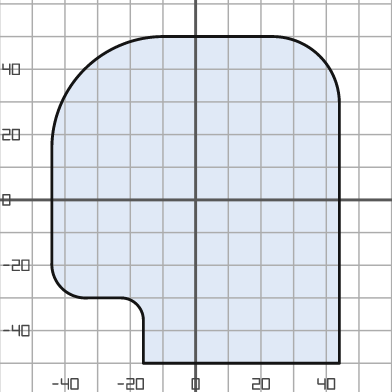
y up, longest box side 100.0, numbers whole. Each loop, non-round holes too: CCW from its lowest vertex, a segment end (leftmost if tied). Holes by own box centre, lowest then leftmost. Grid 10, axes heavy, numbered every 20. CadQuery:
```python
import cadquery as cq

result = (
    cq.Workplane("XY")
    .moveTo(-16.0, -50.0)
    .lineTo(44.0, -50.0)
    .lineTo(44.0, 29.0)
    .threePointArc((38.0, 44.0), (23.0, 50.0))
    .lineTo(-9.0, 50.0)
    .threePointArc((-34.0, 40.0), (-44.0, 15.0))
    .lineTo(-44.0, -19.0)
    .threePointArc((-41.0, -27.0), (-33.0, -30.0))
    .lineTo(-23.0, -30.0)
    .threePointArc((-18.0, -32.0), (-16.0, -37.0))
    .close()
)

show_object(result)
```